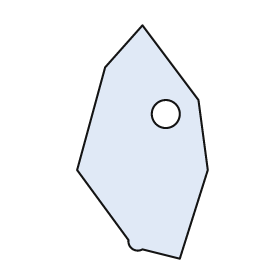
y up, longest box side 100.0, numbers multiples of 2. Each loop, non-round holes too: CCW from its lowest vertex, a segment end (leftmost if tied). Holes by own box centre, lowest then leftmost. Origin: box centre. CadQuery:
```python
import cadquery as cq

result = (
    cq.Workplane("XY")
    .moveTo(16.0, -50.0)
    .lineTo(28.0, -12.0)
    .lineTo(24.0, 18.0)
    .lineTo(0.0, 50.0)
    .lineTo(-16.0, 32.0)
    .lineTo(-28.0, -12.0)
    .lineTo(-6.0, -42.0)
    .threePointArc((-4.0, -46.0), (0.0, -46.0))
    .close()
    .moveTo(10.0, 12.0)
    .circle(6.0)
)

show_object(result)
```